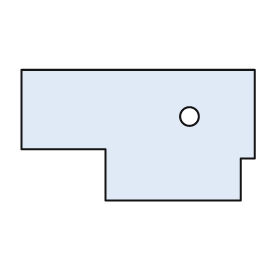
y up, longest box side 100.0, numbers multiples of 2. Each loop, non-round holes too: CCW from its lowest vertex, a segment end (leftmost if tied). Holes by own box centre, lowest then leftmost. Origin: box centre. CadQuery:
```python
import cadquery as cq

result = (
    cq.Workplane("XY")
    .moveTo(-14.0, -28.0)
    .lineTo(44.0, -28.0)
    .lineTo(44.0, -10.0)
    .lineTo(50.0, -10.0)
    .lineTo(50.0, 28.0)
    .lineTo(-50.0, 28.0)
    .lineTo(-50.0, -6.0)
    .lineTo(-14.0, -6.0)
    .close()
    .moveTo(22.0, 8.0)
    .circle(4.0)
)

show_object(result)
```